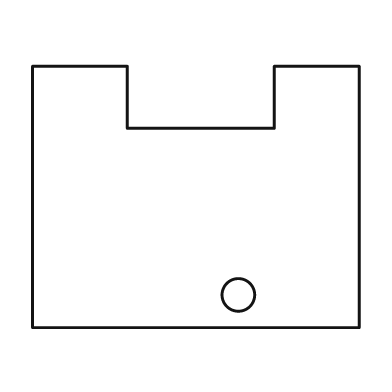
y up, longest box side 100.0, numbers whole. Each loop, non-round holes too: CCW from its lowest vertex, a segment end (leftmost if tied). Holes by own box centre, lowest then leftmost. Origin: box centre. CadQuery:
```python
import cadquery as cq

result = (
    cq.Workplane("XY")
    .moveTo(-50.0, -40.0)
    .lineTo(50.0, -40.0)
    .lineTo(50.0, 40.0)
    .lineTo(24.0, 40.0)
    .lineTo(24.0, 21.0)
    .lineTo(-21.0, 21.0)
    .lineTo(-21.0, 40.0)
    .lineTo(-50.0, 40.0)
    .close()
    .moveTo(13.0, -30.0)
    .circle(5.0)
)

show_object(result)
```